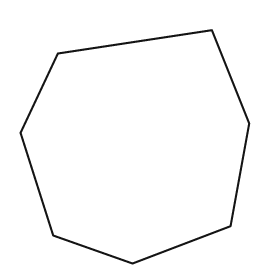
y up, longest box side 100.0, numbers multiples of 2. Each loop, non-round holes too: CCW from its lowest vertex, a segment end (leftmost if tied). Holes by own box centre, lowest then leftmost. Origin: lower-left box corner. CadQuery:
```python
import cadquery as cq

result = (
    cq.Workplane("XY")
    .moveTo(48.0, 0.0)
    .lineTo(90.0, 16.0)
    .lineTo(98.0, 60.0)
    .lineTo(82.0, 100.0)
    .lineTo(16.0, 90.0)
    .lineTo(0.0, 56.0)
    .lineTo(14.0, 12.0)
    .close()
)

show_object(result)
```